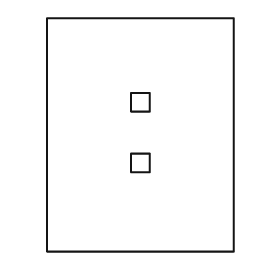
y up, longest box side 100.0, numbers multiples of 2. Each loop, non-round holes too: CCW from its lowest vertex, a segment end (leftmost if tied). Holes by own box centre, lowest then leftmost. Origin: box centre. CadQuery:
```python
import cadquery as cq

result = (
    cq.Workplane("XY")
    .moveTo(-40.0, -50.0)
    .lineTo(40.0, -50.0)
    .lineTo(40.0, 50.0)
    .lineTo(-40.0, 50.0)
    .close()
    .moveTo(-4.0, -16.0)
    .lineTo(4.0, -16.0)
    .lineTo(4.0, -8.0)
    .lineTo(-4.0, -8.0)
    .close()
    .moveTo(-4.0, 10.0)
    .lineTo(4.0, 10.0)
    .lineTo(4.0, 18.0)
    .lineTo(-4.0, 18.0)
    .close()
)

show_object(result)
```